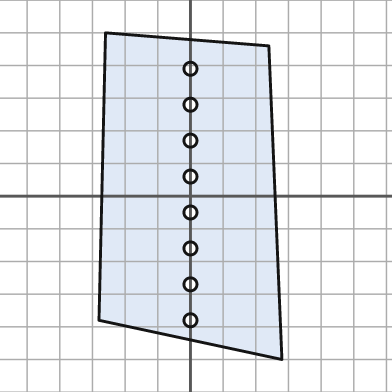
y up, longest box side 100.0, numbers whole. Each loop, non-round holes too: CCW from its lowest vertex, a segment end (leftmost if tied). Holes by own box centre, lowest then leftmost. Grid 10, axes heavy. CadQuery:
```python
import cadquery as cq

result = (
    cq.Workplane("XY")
    .moveTo(28.0, -50.0)
    .lineTo(24.0, 46.0)
    .lineTo(-26.0, 50.0)
    .lineTo(-28.0, -38.0)
    .close()
    .moveTo(0.0, -38.0)
    .circle(2.0)
    .moveTo(0.0, -27.0)
    .circle(2.0)
    .moveTo(0.0, -16.0)
    .circle(2.0)
    .moveTo(0.0, -5.0)
    .circle(2.0)
    .moveTo(0.0, 6.0)
    .circle(2.0)
    .moveTo(0.0, 17.0)
    .circle(2.0)
    .moveTo(0.0, 28.0)
    .circle(2.0)
    .moveTo(0.0, 39.0)
    .circle(2.0)
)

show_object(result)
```